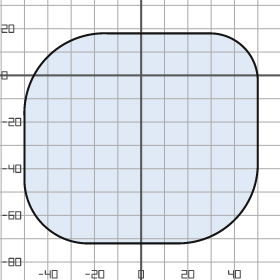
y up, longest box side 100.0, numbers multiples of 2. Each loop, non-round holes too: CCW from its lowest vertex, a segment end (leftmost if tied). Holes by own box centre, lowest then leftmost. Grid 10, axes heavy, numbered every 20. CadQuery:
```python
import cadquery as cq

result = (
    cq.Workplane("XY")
    .moveTo(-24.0, -72.0)
    .lineTo(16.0, -72.0)
    .threePointArc((40.0, -62.0), (50.0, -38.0))
    .lineTo(50.0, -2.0)
    .threePointArc((44.0, 12.0), (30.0, 18.0))
    .lineTo(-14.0, 18.0)
    .threePointArc((-40.0, 8.0), (-50.0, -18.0))
    .lineTo(-50.0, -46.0)
    .threePointArc((-42.0, -64.0), (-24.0, -72.0))
    .close()
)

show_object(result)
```